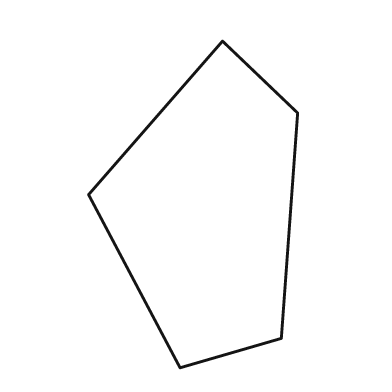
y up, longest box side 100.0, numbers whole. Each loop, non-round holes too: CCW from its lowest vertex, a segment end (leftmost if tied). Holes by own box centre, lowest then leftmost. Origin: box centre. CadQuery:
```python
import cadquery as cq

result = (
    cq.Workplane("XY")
    .moveTo(-4.0, -50.0)
    .lineTo(27.0, -41.0)
    .lineTo(32.0, 28.0)
    .lineTo(9.0, 50.0)
    .lineTo(-32.0, 3.0)
    .close()
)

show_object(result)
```